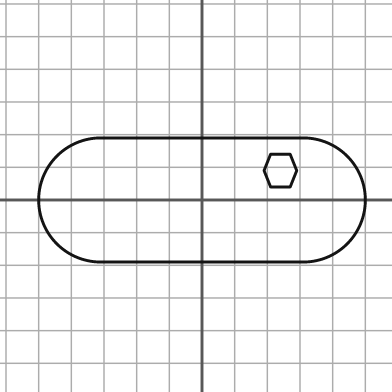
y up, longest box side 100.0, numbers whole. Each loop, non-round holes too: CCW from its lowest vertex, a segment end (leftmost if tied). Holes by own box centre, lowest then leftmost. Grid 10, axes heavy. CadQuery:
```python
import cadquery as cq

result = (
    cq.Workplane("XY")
    .moveTo(-31.0, -19.0)
    .lineTo(31.0, -19.0)
    .threePointArc((50.0, 0.0), (31.0, 19.0))
    .lineTo(-31.0, 19.0)
    .threePointArc((-50.0, 0.0), (-31.0, -19.0))
    .close()
    .moveTo(21.0, 4.0)
    .lineTo(27.0, 4.0)
    .lineTo(29.0, 9.0)
    .lineTo(27.0, 14.0)
    .lineTo(21.0, 14.0)
    .lineTo(19.0, 9.0)
    .close()
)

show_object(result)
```